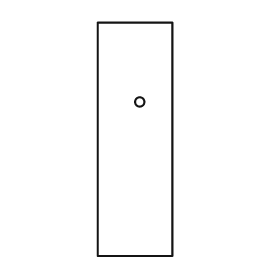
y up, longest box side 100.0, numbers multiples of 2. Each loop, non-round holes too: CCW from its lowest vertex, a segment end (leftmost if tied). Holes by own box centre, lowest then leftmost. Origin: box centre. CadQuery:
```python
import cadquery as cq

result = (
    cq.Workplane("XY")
    .moveTo(-16.0, -50.0)
    .lineTo(16.0, -50.0)
    .lineTo(16.0, 50.0)
    .lineTo(-16.0, 50.0)
    .close()
    .moveTo(2.0, 16.0)
    .circle(2.0)
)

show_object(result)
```